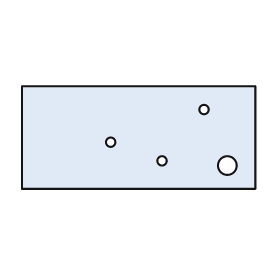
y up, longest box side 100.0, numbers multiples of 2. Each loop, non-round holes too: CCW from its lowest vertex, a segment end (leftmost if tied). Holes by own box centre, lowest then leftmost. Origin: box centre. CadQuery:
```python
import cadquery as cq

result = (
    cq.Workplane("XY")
    .moveTo(-50.0, -22.0)
    .lineTo(50.0, -22.0)
    .lineTo(50.0, 22.0)
    .lineTo(-50.0, 22.0)
    .close()
    .moveTo(38.0, -12.0)
    .circle(4.0)
    .moveTo(10.0, -10.0)
    .circle(2.0)
    .moveTo(-12.0, -2.0)
    .circle(2.0)
    .moveTo(28.0, 12.0)
    .circle(2.0)
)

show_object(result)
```